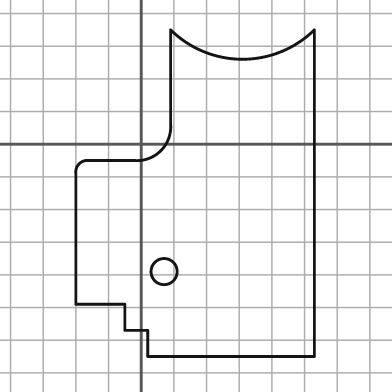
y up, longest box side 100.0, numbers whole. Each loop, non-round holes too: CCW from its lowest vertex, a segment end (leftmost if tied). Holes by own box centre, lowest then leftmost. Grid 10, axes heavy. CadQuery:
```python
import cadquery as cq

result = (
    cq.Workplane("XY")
    .moveTo(2.0, -65.0)
    .lineTo(53.0, -65.0)
    .lineTo(53.0, 35.0)
    .threePointArc((31.0, 26.0), (9.0, 35.0))
    .lineTo(9.0, 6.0)
    .threePointArc((6.0, -2.0), (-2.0, -5.0))
    .lineTo(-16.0, -5.0)
    .threePointArc((-19.0, -6.0), (-20.0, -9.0))
    .lineTo(-20.0, -49.0)
    .lineTo(-5.0, -49.0)
    .lineTo(-5.0, -57.0)
    .lineTo(2.0, -57.0)
    .close()
    .moveTo(7.0, -39.0)
    .circle(4.0)
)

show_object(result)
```